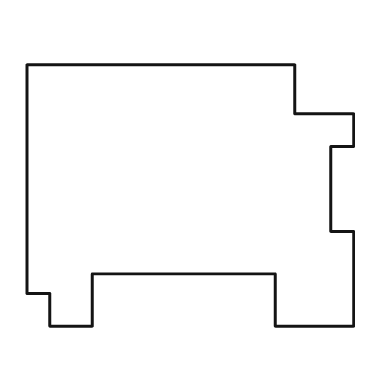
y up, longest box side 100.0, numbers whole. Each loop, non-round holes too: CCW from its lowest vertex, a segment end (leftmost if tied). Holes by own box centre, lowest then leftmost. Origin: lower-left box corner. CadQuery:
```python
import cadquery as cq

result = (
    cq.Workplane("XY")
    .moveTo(7.0, 0.0)
    .lineTo(20.0, 0.0)
    .lineTo(20.0, 16.0)
    .lineTo(76.0, 16.0)
    .lineTo(76.0, 0.0)
    .lineTo(100.0, 0.0)
    .lineTo(100.0, 29.0)
    .lineTo(93.0, 29.0)
    .lineTo(93.0, 55.0)
    .lineTo(100.0, 55.0)
    .lineTo(100.0, 65.0)
    .lineTo(82.0, 65.0)
    .lineTo(82.0, 80.0)
    .lineTo(0.0, 80.0)
    .lineTo(0.0, 10.0)
    .lineTo(7.0, 10.0)
    .close()
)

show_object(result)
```